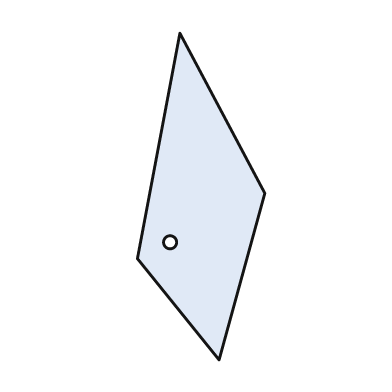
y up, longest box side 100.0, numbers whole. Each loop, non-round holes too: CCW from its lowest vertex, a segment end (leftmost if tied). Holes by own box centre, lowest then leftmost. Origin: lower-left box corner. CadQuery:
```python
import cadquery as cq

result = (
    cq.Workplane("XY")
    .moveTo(25.0, 0.0)
    .lineTo(39.0, 51.0)
    .lineTo(13.0, 100.0)
    .lineTo(0.0, 31.0)
    .close()
    .moveTo(10.0, 36.0)
    .circle(2.0)
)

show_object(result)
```